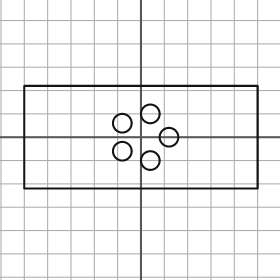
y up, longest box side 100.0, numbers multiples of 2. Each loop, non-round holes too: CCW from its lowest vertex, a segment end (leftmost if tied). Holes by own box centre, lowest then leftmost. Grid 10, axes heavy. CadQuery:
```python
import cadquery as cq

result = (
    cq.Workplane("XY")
    .moveTo(-50.0, -22.0)
    .lineTo(50.0, -22.0)
    .lineTo(50.0, 22.0)
    .lineTo(-50.0, 22.0)
    .close()
    .moveTo(4.0, -10.0)
    .circle(4.0)
    .moveTo(-8.0, -6.0)
    .circle(4.0)
    .moveTo(12.0, 0.0)
    .circle(4.0)
    .moveTo(-8.0, 6.0)
    .circle(4.0)
    .moveTo(4.0, 10.0)
    .circle(4.0)
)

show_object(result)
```